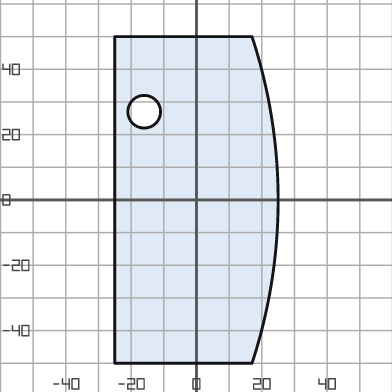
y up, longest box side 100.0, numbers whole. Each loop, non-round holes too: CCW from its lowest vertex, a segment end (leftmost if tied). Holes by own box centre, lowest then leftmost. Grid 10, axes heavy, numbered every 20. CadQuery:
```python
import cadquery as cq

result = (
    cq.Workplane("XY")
    .moveTo(-25.0, -50.0)
    .lineTo(17.0, -50.0)
    .threePointArc((25.0, 0.0), (17.0, 50.0))
    .lineTo(-25.0, 50.0)
    .close()
    .moveTo(-16.0, 27.0)
    .circle(5.0)
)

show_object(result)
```